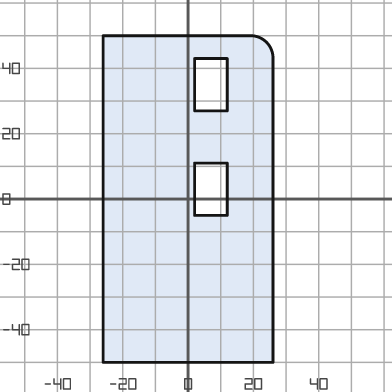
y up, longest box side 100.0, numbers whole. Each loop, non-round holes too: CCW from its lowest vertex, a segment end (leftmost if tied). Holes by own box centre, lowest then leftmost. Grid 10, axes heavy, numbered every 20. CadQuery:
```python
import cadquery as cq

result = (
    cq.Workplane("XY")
    .moveTo(-26.0, -50.0)
    .lineTo(26.0, -50.0)
    .lineTo(26.0, 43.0)
    .threePointArc((24.0, 48.0), (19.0, 50.0))
    .lineTo(-26.0, 50.0)
    .close()
    .moveTo(2.0, -5.0)
    .lineTo(12.0, -5.0)
    .lineTo(12.0, 11.0)
    .lineTo(2.0, 11.0)
    .close()
    .moveTo(2.0, 27.0)
    .lineTo(12.0, 27.0)
    .lineTo(12.0, 43.0)
    .lineTo(2.0, 43.0)
    .close()
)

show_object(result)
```